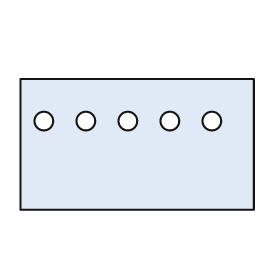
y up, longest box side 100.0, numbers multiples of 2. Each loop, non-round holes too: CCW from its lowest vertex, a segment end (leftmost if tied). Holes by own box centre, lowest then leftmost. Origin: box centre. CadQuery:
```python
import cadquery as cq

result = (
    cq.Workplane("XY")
    .moveTo(-50.0, -28.0)
    .lineTo(50.0, -28.0)
    .lineTo(50.0, 28.0)
    .lineTo(-50.0, 28.0)
    .close()
    .moveTo(-40.0, 10.0)
    .circle(4.0)
    .moveTo(-22.0, 10.0)
    .circle(4.0)
    .moveTo(-4.0, 10.0)
    .circle(4.0)
    .moveTo(14.0, 10.0)
    .circle(4.0)
    .moveTo(32.0, 10.0)
    .circle(4.0)
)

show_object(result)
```